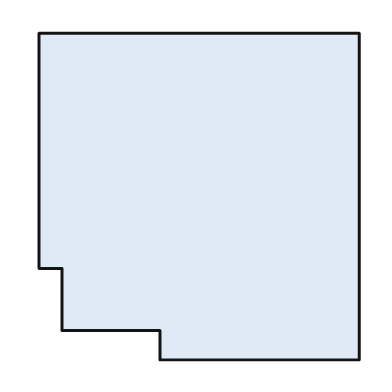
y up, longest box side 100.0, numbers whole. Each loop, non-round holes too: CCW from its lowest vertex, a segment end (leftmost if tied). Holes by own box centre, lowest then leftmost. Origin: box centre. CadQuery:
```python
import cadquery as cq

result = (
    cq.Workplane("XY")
    .moveTo(-12.0, -50.0)
    .lineTo(49.0, -50.0)
    .lineTo(49.0, 50.0)
    .lineTo(-49.0, 50.0)
    .lineTo(-49.0, -22.0)
    .lineTo(-42.0, -22.0)
    .lineTo(-42.0, -41.0)
    .lineTo(-12.0, -41.0)
    .close()
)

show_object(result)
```